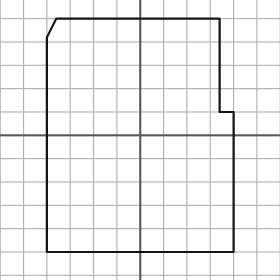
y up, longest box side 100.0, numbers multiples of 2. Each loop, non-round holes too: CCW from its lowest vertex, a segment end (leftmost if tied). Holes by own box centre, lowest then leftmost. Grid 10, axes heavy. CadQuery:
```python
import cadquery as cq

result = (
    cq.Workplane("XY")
    .moveTo(-40.0, -50.0)
    .lineTo(40.0, -50.0)
    .lineTo(40.0, 10.0)
    .lineTo(34.0, 10.0)
    .lineTo(34.0, 50.0)
    .lineTo(-36.0, 50.0)
    .lineTo(-40.0, 42.0)
    .close()
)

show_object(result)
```